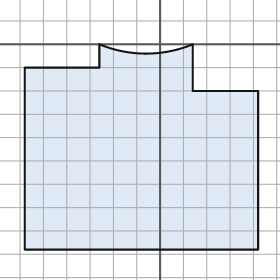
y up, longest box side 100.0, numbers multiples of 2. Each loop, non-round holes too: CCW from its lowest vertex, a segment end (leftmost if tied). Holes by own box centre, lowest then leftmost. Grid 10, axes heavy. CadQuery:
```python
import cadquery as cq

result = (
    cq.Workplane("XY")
    .moveTo(-58.0, -88.0)
    .lineTo(42.0, -88.0)
    .lineTo(42.0, -20.0)
    .lineTo(14.0, -20.0)
    .lineTo(14.0, 0.0)
    .threePointArc((-6.0, -4.0), (-26.0, 0.0))
    .lineTo(-26.0, -10.0)
    .lineTo(-58.0, -10.0)
    .close()
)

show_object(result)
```